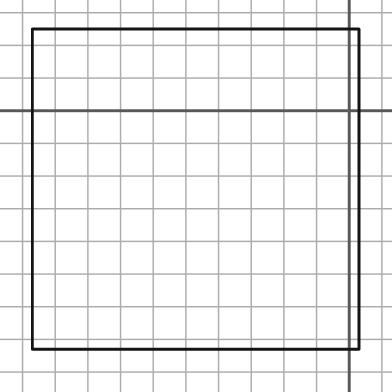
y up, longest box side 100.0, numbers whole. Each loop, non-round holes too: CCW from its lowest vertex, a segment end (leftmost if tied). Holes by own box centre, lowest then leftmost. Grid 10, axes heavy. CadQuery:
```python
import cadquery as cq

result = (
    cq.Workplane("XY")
    .moveTo(-97.0, -73.0)
    .lineTo(3.0, -73.0)
    .lineTo(3.0, 25.0)
    .lineTo(-97.0, 25.0)
    .close()
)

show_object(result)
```